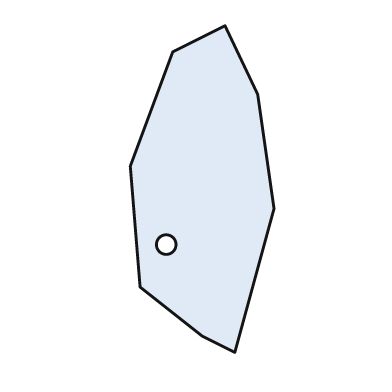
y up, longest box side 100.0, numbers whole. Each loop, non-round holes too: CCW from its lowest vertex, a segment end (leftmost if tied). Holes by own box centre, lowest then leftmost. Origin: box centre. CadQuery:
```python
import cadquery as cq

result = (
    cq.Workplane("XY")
    .moveTo(10.0, -50.0)
    .lineTo(22.0, -6.0)
    .lineTo(17.0, 29.0)
    .lineTo(7.0, 50.0)
    .lineTo(-9.0, 42.0)
    .lineTo(-22.0, 7.0)
    .lineTo(-19.0, -30.0)
    .lineTo(0.0, -45.0)
    .close()
    .moveTo(-11.0, -17.0)
    .circle(3.0)
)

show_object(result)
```